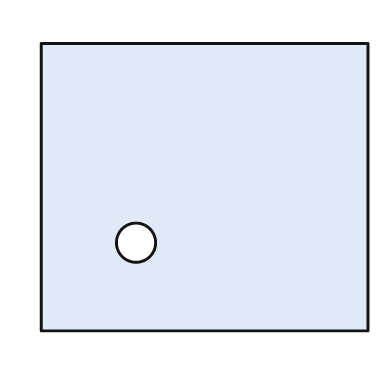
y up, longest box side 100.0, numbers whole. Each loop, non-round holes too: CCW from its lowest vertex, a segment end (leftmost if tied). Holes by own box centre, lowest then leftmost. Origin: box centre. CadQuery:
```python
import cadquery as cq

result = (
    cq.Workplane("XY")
    .moveTo(-50.0, -44.0)
    .lineTo(50.0, -44.0)
    .lineTo(50.0, 44.0)
    .lineTo(-50.0, 44.0)
    .close()
    .moveTo(-21.0, -17.0)
    .circle(6.0)
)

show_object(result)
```